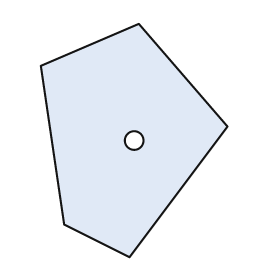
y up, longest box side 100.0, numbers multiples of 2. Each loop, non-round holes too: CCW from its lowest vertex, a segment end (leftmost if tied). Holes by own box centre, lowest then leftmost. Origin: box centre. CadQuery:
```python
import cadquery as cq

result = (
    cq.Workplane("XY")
    .moveTo(-2.0, -50.0)
    .lineTo(40.0, 6.0)
    .lineTo(2.0, 50.0)
    .lineTo(-40.0, 32.0)
    .lineTo(-30.0, -36.0)
    .close()
    .moveTo(0.0, 0.0)
    .circle(4.0)
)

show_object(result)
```